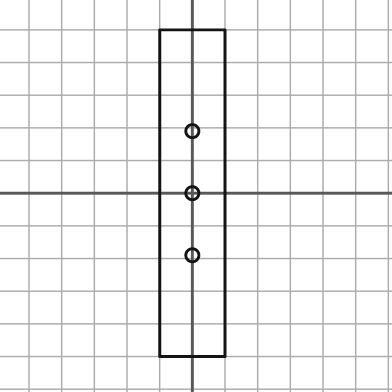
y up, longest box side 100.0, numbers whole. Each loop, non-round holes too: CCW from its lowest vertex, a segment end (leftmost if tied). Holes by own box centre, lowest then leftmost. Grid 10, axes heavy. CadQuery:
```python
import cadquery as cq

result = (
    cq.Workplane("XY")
    .moveTo(-10.0, -50.0)
    .lineTo(10.0, -50.0)
    .lineTo(10.0, 50.0)
    .lineTo(-10.0, 50.0)
    .close()
    .moveTo(0.0, -19.0)
    .circle(2.0)
    .moveTo(0.0, 0.0)
    .circle(2.0)
    .moveTo(0.0, 19.0)
    .circle(2.0)
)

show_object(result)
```